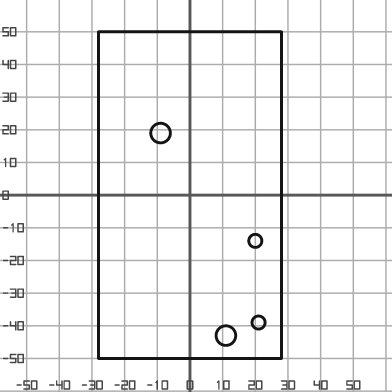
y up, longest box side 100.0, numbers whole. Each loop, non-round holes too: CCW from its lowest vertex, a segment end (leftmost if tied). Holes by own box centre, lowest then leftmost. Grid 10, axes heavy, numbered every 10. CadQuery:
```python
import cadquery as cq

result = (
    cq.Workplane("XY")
    .moveTo(-28.0, -50.0)
    .lineTo(28.0, -50.0)
    .lineTo(28.0, 50.0)
    .lineTo(-28.0, 50.0)
    .close()
    .moveTo(11.0, -43.0)
    .circle(3.0)
    .moveTo(21.0, -39.0)
    .circle(2.0)
    .moveTo(20.0, -14.0)
    .circle(2.0)
    .moveTo(-9.0, 19.0)
    .circle(3.0)
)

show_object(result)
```